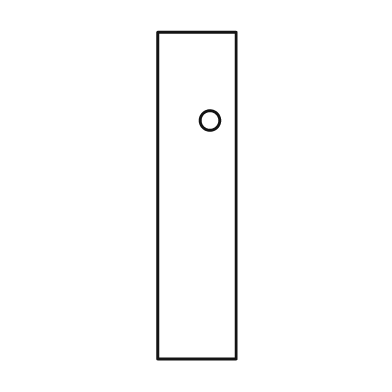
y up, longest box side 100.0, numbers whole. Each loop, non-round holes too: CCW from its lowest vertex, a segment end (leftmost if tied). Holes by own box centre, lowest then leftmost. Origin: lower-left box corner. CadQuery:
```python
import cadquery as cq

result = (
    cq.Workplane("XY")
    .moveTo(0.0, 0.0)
    .lineTo(24.0, 0.0)
    .lineTo(24.0, 100.0)
    .lineTo(0.0, 100.0)
    .close()
    .moveTo(16.0, 73.0)
    .circle(3.0)
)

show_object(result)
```